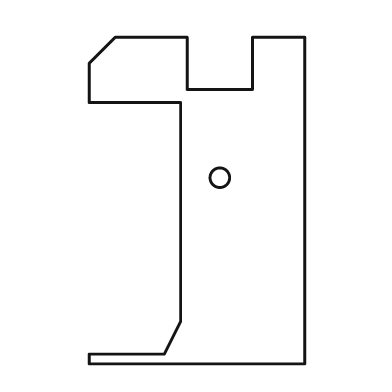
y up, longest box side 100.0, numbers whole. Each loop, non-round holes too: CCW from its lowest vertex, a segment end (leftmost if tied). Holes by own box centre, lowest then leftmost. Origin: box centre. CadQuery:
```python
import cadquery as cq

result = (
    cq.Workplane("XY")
    .moveTo(-33.0, -50.0)
    .lineTo(33.0, -50.0)
    .lineTo(33.0, 50.0)
    .lineTo(17.0, 50.0)
    .lineTo(17.0, 34.0)
    .lineTo(-3.0, 34.0)
    .lineTo(-3.0, 50.0)
    .lineTo(-25.0, 50.0)
    .lineTo(-33.0, 42.0)
    .lineTo(-33.0, 30.0)
    .lineTo(-5.0, 30.0)
    .lineTo(-5.0, -37.0)
    .lineTo(-10.0, -47.0)
    .lineTo(-33.0, -47.0)
    .close()
    .moveTo(7.0, 7.0)
    .circle(3.0)
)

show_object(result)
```